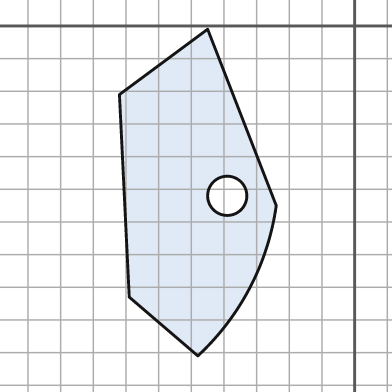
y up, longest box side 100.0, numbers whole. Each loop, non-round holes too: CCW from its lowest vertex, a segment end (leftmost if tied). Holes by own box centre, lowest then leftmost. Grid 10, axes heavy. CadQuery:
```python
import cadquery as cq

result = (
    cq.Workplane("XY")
    .moveTo(-48.0, -101.0)
    .threePointArc((-32.0, -80.0), (-24.0, -55.0))
    .lineTo(-45.0, -1.0)
    .lineTo(-72.0, -21.0)
    .lineTo(-69.0, -83.0)
    .close()
    .moveTo(-39.0, -52.0)
    .circle(6.0)
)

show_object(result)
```